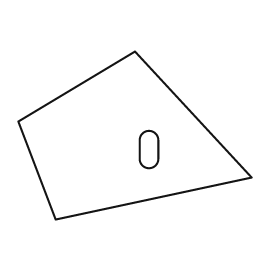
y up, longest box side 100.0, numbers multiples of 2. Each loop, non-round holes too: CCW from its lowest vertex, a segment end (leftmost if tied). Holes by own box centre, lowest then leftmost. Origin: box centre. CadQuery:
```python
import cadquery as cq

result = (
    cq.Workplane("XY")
    .moveTo(-34.0, -36.0)
    .lineTo(50.0, -18.0)
    .lineTo(0.0, 36.0)
    .lineTo(-50.0, 6.0)
    .close()
    .moveTo(2.0, -10.0)
    .threePointArc((6.0, -14.0), (10.0, -10.0))
    .lineTo(10.0, -2.0)
    .threePointArc((6.0, 2.0), (2.0, -2.0))
    .close()
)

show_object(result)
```